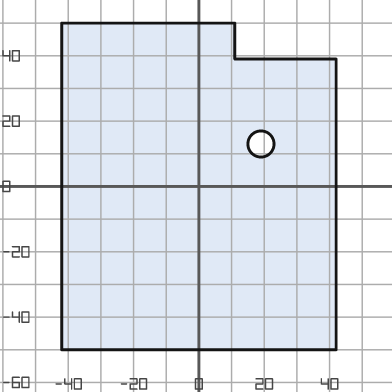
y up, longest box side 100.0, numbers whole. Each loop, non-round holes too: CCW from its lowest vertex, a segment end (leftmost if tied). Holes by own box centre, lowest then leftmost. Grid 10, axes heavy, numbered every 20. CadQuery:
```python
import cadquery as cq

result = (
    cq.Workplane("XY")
    .moveTo(-42.0, -50.0)
    .lineTo(42.0, -50.0)
    .lineTo(42.0, 39.0)
    .lineTo(11.0, 39.0)
    .lineTo(11.0, 50.0)
    .lineTo(-42.0, 50.0)
    .close()
    .moveTo(19.0, 13.0)
    .circle(4.0)
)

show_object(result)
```